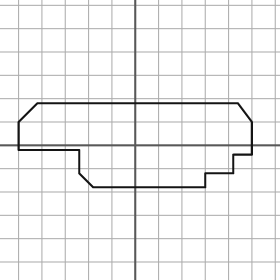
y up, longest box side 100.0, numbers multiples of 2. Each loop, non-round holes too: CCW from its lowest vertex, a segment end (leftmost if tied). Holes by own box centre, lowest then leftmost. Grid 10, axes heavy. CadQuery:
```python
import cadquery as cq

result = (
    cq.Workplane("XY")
    .moveTo(-18.0, -18.0)
    .lineTo(30.0, -18.0)
    .lineTo(30.0, -12.0)
    .lineTo(42.0, -12.0)
    .lineTo(42.0, -4.0)
    .lineTo(50.0, -4.0)
    .lineTo(50.0, 10.0)
    .lineTo(44.0, 18.0)
    .lineTo(-42.0, 18.0)
    .lineTo(-50.0, 10.0)
    .lineTo(-50.0, -2.0)
    .lineTo(-24.0, -2.0)
    .lineTo(-24.0, -12.0)
    .close()
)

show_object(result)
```